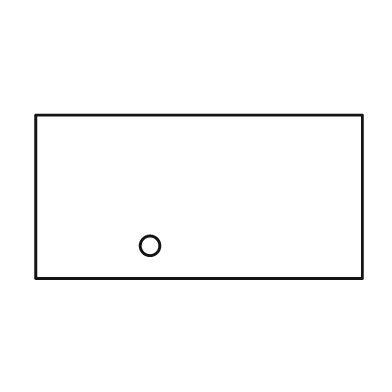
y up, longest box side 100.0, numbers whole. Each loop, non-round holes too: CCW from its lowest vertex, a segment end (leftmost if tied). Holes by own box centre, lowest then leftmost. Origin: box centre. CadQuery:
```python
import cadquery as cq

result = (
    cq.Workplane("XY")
    .moveTo(-50.0, -25.0)
    .lineTo(50.0, -25.0)
    .lineTo(50.0, 25.0)
    .lineTo(-50.0, 25.0)
    .close()
    .moveTo(-15.0, -15.0)
    .circle(3.0)
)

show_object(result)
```